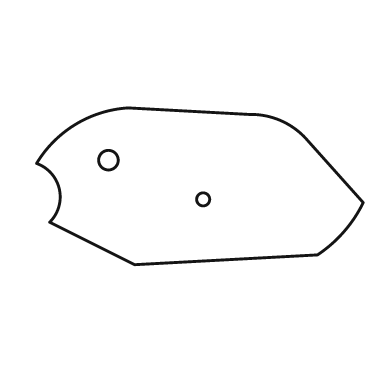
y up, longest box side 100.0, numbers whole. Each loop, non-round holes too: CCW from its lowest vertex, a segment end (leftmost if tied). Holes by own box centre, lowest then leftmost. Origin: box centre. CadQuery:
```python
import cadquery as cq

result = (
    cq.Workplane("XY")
    .moveTo(-20.0, -24.0)
    .lineTo(36.0, -21.0)
    .threePointArc((44.0, -14.0), (50.0, -5.0))
    .lineTo(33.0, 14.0)
    .threePointArc((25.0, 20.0), (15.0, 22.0))
    .lineTo(-22.0, 24.0)
    .threePointArc((-38.0, 19.0), (-50.0, 7.0))
    .threePointArc((-43.0, -1.0), (-46.0, -11.0))
    .close()
    .moveTo(1.0, -4.0)
    .circle(2.0)
    .moveTo(-28.0, 8.0)
    .circle(3.0)
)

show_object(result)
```